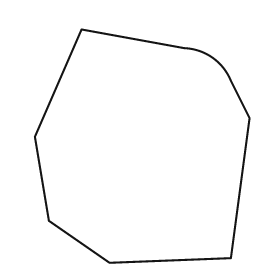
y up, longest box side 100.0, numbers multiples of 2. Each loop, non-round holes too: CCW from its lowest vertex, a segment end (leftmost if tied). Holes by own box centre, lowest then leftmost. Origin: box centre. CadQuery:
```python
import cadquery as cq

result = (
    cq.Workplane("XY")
    .moveTo(-14.0, -50.0)
    .lineTo(38.0, -48.0)
    .lineTo(46.0, 12.0)
    .lineTo(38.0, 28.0)
    .threePointArc((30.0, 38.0), (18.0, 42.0))
    .lineTo(-26.0, 50.0)
    .lineTo(-46.0, 4.0)
    .lineTo(-40.0, -32.0)
    .close()
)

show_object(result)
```